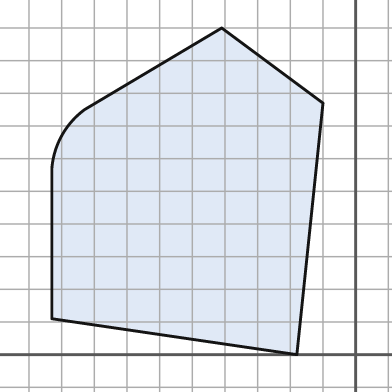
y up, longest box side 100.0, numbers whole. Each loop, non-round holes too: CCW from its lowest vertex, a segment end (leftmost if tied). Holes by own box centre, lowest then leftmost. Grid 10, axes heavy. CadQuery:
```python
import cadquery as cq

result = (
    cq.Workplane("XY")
    .moveTo(-18.0, 0.0)
    .lineTo(-10.0, 77.0)
    .lineTo(-41.0, 100.0)
    .lineTo(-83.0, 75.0)
    .threePointArc((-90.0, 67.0), (-93.0, 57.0))
    .lineTo(-93.0, 11.0)
    .close()
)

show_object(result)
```